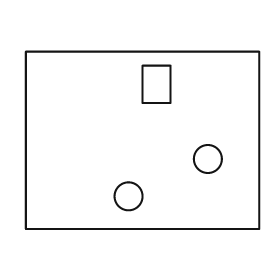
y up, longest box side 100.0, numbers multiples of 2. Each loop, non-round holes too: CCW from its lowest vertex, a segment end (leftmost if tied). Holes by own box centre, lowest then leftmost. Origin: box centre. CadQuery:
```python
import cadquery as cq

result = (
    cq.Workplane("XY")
    .moveTo(-50.0, -38.0)
    .lineTo(50.0, -38.0)
    .lineTo(50.0, 38.0)
    .lineTo(-50.0, 38.0)
    .close()
    .moveTo(-6.0, -24.0)
    .circle(6.0)
    .moveTo(28.0, -8.0)
    .circle(6.0)
    .moveTo(0.0, 16.0)
    .lineTo(12.0, 16.0)
    .lineTo(12.0, 32.0)
    .lineTo(0.0, 32.0)
    .close()
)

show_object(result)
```